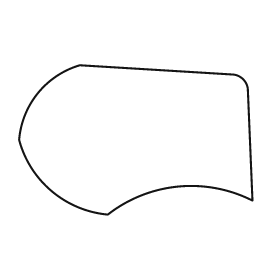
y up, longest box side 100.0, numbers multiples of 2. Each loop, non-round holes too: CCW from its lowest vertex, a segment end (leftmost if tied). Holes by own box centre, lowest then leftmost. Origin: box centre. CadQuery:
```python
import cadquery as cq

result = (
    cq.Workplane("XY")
    .moveTo(-12.0, -32.0)
    .threePointArc((18.0, -20.0), (50.0, -26.0))
    .lineTo(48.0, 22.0)
    .threePointArc((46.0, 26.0), (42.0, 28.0))
    .lineTo(-24.0, 32.0)
    .threePointArc((-42.0, 20.0), (-50.0, 0.0))
    .threePointArc((-36.0, -22.0), (-12.0, -32.0))
    .close()
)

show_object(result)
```